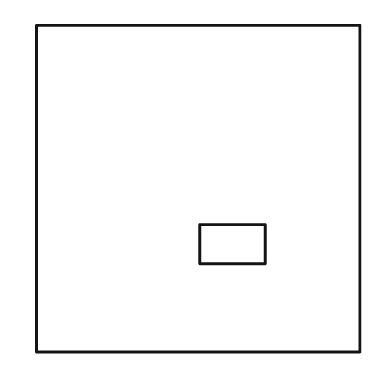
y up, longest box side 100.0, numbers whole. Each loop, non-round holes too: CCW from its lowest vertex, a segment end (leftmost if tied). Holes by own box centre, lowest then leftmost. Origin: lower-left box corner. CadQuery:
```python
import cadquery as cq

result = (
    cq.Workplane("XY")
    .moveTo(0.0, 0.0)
    .lineTo(99.0, 0.0)
    .lineTo(99.0, 100.0)
    .lineTo(0.0, 100.0)
    .close()
    .moveTo(50.0, 27.0)
    .lineTo(70.0, 27.0)
    .lineTo(70.0, 39.0)
    .lineTo(50.0, 39.0)
    .close()
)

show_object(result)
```